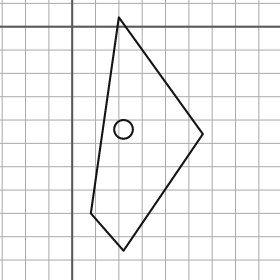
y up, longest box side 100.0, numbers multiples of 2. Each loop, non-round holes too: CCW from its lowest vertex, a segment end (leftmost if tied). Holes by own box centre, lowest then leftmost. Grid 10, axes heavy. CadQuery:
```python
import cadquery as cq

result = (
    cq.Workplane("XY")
    .moveTo(22.0, -96.0)
    .lineTo(56.0, -46.0)
    .lineTo(20.0, 4.0)
    .lineTo(8.0, -80.0)
    .close()
    .moveTo(22.0, -44.0)
    .circle(4.0)
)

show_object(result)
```